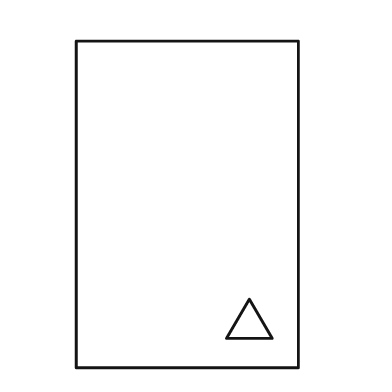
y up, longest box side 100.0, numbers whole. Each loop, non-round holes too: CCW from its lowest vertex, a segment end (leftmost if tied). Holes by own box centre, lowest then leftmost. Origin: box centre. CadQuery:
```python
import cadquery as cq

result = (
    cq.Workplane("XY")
    .moveTo(-34.0, -50.0)
    .lineTo(34.0, -50.0)
    .lineTo(34.0, 50.0)
    .lineTo(-34.0, 50.0)
    .close()
    .moveTo(12.0, -41.0)
    .lineTo(26.0, -41.0)
    .lineTo(19.0, -29.0)
    .close()
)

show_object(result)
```